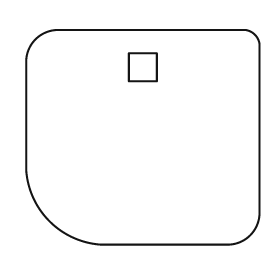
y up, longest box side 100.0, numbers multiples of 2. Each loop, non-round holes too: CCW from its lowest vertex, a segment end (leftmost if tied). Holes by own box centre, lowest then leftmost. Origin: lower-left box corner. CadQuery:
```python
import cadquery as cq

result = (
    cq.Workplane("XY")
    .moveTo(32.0, 0.0)
    .lineTo(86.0, 0.0)
    .threePointArc((96.0, 4.0), (100.0, 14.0))
    .lineTo(100.0, 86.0)
    .threePointArc((98.0, 90.0), (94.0, 92.0))
    .lineTo(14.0, 92.0)
    .threePointArc((4.0, 88.0), (0.0, 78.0))
    .lineTo(0.0, 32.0)
    .threePointArc((10.0, 10.0), (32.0, 0.0))
    .close()
    .moveTo(44.0, 70.0)
    .lineTo(56.0, 70.0)
    .lineTo(56.0, 82.0)
    .lineTo(44.0, 82.0)
    .close()
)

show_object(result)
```